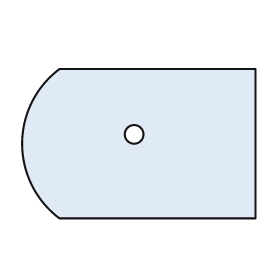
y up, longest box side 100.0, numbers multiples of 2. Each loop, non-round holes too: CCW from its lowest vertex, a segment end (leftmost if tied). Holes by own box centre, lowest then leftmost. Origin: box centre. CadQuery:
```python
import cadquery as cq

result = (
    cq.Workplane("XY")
    .moveTo(-34.0, -32.0)
    .lineTo(50.0, -32.0)
    .lineTo(50.0, 32.0)
    .lineTo(-34.0, 32.0)
    .threePointArc((-50.0, 0.0), (-34.0, -32.0))
    .close()
    .moveTo(-2.0, 4.0)
    .circle(4.0)
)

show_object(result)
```